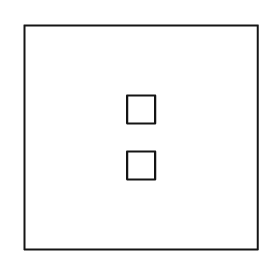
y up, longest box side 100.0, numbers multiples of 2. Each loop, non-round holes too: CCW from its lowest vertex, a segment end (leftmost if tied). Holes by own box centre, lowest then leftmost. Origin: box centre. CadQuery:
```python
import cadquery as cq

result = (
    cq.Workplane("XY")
    .moveTo(-50.0, -48.0)
    .lineTo(50.0, -48.0)
    .lineTo(50.0, 48.0)
    .lineTo(-50.0, 48.0)
    .close()
    .moveTo(-6.0, -18.0)
    .lineTo(6.0, -18.0)
    .lineTo(6.0, -6.0)
    .lineTo(-6.0, -6.0)
    .close()
    .moveTo(-6.0, 6.0)
    .lineTo(6.0, 6.0)
    .lineTo(6.0, 18.0)
    .lineTo(-6.0, 18.0)
    .close()
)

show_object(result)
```